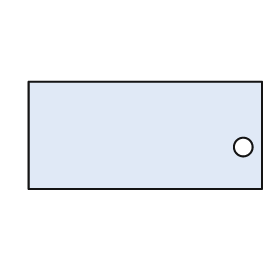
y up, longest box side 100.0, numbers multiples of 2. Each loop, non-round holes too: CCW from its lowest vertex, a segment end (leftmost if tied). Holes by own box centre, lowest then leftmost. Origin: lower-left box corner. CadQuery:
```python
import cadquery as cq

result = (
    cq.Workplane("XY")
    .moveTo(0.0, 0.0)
    .lineTo(100.0, 0.0)
    .lineTo(100.0, 46.0)
    .lineTo(0.0, 46.0)
    .close()
    .moveTo(92.0, 18.0)
    .circle(4.0)
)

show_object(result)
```